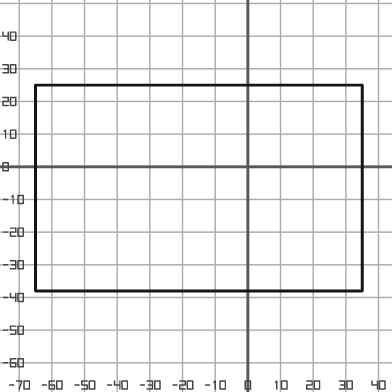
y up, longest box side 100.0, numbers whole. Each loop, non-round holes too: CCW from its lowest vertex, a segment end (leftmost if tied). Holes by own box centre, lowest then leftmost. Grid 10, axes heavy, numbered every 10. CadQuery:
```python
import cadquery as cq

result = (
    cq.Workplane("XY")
    .moveTo(-65.0, -38.0)
    .lineTo(35.0, -38.0)
    .lineTo(35.0, 25.0)
    .lineTo(-65.0, 25.0)
    .close()
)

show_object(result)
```